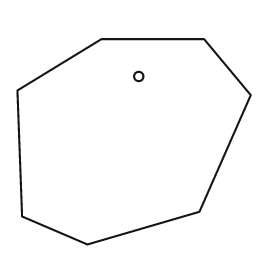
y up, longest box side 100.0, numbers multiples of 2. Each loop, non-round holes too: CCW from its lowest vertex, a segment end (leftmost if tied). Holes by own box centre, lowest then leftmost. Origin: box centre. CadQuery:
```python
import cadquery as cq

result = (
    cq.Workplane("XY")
    .moveTo(-20.0, -44.0)
    .lineTo(28.0, -30.0)
    .lineTo(50.0, 20.0)
    .lineTo(30.0, 44.0)
    .lineTo(-14.0, 44.0)
    .lineTo(-50.0, 22.0)
    .lineTo(-48.0, -32.0)
    .close()
    .moveTo(2.0, 28.0)
    .circle(2.0)
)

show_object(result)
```